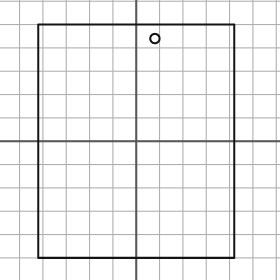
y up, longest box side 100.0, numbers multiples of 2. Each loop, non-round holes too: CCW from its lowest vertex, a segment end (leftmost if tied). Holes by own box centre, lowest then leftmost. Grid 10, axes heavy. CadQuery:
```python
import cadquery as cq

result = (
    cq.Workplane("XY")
    .moveTo(-42.0, -50.0)
    .lineTo(42.0, -50.0)
    .lineTo(42.0, 50.0)
    .lineTo(-42.0, 50.0)
    .close()
    .moveTo(8.0, 44.0)
    .circle(2.0)
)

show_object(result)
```